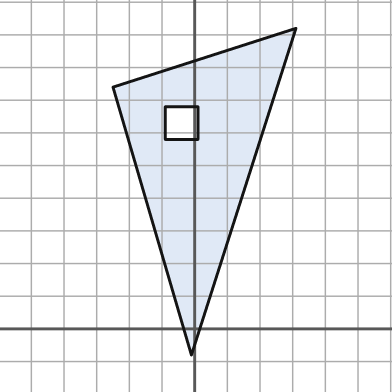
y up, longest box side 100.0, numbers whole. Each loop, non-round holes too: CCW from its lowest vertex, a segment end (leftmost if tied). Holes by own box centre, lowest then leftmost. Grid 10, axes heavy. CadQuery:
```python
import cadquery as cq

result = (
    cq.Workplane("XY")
    .moveTo(-1.0, -8.0)
    .lineTo(31.0, 92.0)
    .lineTo(-25.0, 74.0)
    .close()
    .moveTo(-9.0, 58.0)
    .lineTo(1.0, 58.0)
    .lineTo(1.0, 68.0)
    .lineTo(-9.0, 68.0)
    .close()
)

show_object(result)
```